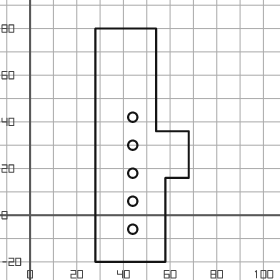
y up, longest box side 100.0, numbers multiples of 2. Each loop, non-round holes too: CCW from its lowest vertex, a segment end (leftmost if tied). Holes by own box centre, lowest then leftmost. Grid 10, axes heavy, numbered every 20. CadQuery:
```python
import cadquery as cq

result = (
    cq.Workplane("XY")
    .moveTo(28.0, -20.0)
    .lineTo(58.0, -20.0)
    .lineTo(58.0, 16.0)
    .lineTo(68.0, 16.0)
    .lineTo(68.0, 36.0)
    .lineTo(54.0, 36.0)
    .lineTo(54.0, 80.0)
    .lineTo(28.0, 80.0)
    .close()
    .moveTo(44.0, -6.0)
    .circle(2.0)
    .moveTo(44.0, 6.0)
    .circle(2.0)
    .moveTo(44.0, 18.0)
    .circle(2.0)
    .moveTo(44.0, 30.0)
    .circle(2.0)
    .moveTo(44.0, 42.0)
    .circle(2.0)
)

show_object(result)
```